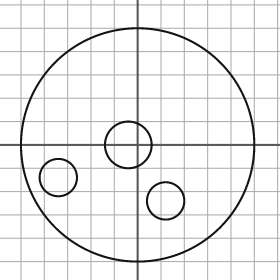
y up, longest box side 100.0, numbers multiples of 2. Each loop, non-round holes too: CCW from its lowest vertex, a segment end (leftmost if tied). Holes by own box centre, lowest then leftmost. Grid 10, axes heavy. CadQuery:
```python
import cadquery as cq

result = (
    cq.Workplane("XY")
    .moveTo(0.0, 0.0)
    .circle(50.0)
    .moveTo(12.0, -24.0)
    .circle(8.0)
    .moveTo(-34.0, -14.0)
    .circle(8.0)
    .moveTo(-4.0, 0.0)
    .circle(10.0)
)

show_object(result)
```